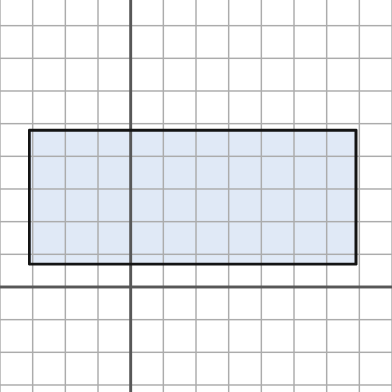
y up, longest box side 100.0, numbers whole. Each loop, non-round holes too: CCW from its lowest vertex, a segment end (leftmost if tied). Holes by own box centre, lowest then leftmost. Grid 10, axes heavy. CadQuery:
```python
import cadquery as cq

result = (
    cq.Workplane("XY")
    .moveTo(-31.0, 7.0)
    .lineTo(69.0, 7.0)
    .lineTo(69.0, 48.0)
    .lineTo(-31.0, 48.0)
    .close()
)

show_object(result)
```